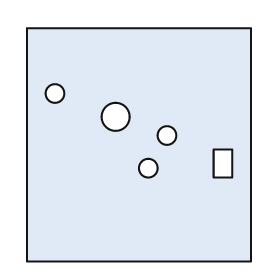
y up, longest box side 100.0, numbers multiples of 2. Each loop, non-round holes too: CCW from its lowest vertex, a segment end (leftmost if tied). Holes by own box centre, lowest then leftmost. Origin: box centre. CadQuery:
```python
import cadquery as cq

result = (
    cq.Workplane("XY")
    .moveTo(-48.0, -50.0)
    .lineTo(48.0, -50.0)
    .lineTo(48.0, 50.0)
    .lineTo(-48.0, 50.0)
    .close()
    .moveTo(4.0, -10.0)
    .circle(4.0)
    .moveTo(32.0, -14.0)
    .lineTo(40.0, -14.0)
    .lineTo(40.0, -2.0)
    .lineTo(32.0, -2.0)
    .close()
    .moveTo(12.0, 4.0)
    .circle(4.0)
    .moveTo(-10.0, 12.0)
    .circle(6.0)
    .moveTo(-36.0, 22.0)
    .circle(4.0)
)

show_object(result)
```